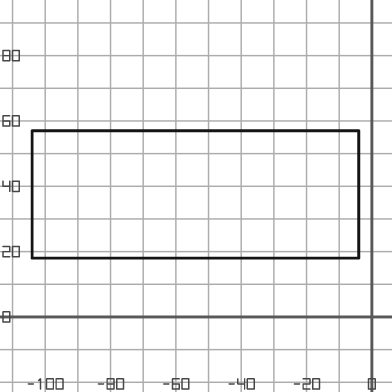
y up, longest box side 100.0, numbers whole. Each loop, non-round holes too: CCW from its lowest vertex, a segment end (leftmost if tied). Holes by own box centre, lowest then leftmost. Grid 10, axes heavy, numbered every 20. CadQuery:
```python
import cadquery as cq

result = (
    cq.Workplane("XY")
    .moveTo(-104.0, 18.0)
    .lineTo(-4.0, 18.0)
    .lineTo(-4.0, 57.0)
    .lineTo(-104.0, 57.0)
    .close()
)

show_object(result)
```